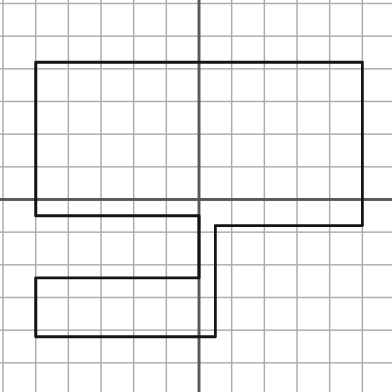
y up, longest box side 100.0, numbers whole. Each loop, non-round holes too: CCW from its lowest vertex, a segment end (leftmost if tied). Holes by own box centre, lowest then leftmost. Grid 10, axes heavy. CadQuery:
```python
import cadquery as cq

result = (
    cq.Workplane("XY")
    .moveTo(-50.0, -42.0)
    .lineTo(5.0, -42.0)
    .lineTo(5.0, -8.0)
    .lineTo(50.0, -8.0)
    .lineTo(50.0, 42.0)
    .lineTo(-50.0, 42.0)
    .lineTo(-50.0, -5.0)
    .lineTo(0.0, -5.0)
    .lineTo(0.0, -24.0)
    .lineTo(-50.0, -24.0)
    .close()
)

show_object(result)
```